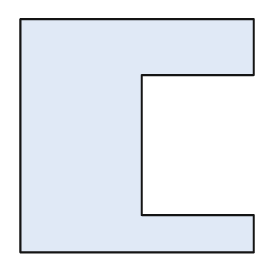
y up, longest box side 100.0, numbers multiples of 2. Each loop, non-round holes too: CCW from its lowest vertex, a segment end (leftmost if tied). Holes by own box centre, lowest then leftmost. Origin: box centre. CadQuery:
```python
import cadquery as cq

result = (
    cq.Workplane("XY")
    .moveTo(-50.0, -50.0)
    .lineTo(50.0, -50.0)
    .lineTo(50.0, -34.0)
    .lineTo(2.0, -34.0)
    .lineTo(2.0, 26.0)
    .lineTo(50.0, 26.0)
    .lineTo(50.0, 50.0)
    .lineTo(-50.0, 50.0)
    .close()
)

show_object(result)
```